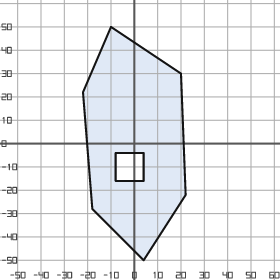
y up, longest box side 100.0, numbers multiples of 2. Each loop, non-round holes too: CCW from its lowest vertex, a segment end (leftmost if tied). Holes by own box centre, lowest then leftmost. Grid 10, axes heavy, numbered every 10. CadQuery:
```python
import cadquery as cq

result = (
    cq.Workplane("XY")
    .moveTo(4.0, -50.0)
    .lineTo(22.0, -22.0)
    .lineTo(20.0, 30.0)
    .lineTo(-10.0, 50.0)
    .lineTo(-22.0, 22.0)
    .lineTo(-18.0, -28.0)
    .close()
    .moveTo(-8.0, -16.0)
    .lineTo(4.0, -16.0)
    .lineTo(4.0, -4.0)
    .lineTo(-8.0, -4.0)
    .close()
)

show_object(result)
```